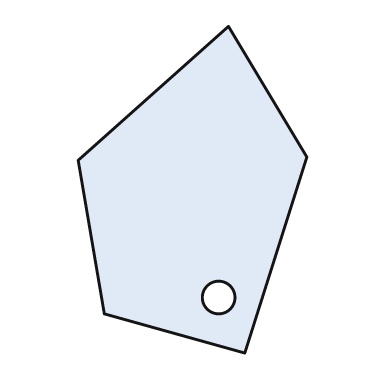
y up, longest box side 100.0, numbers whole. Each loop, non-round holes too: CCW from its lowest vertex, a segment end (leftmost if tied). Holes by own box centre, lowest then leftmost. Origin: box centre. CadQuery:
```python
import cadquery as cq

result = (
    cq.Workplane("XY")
    .moveTo(16.0, -50.0)
    .lineTo(35.0, 10.0)
    .lineTo(11.0, 50.0)
    .lineTo(-35.0, 9.0)
    .lineTo(-27.0, -38.0)
    .close()
    .moveTo(8.0, -33.0)
    .circle(5.0)
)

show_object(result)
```